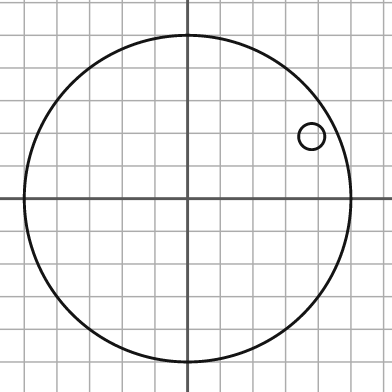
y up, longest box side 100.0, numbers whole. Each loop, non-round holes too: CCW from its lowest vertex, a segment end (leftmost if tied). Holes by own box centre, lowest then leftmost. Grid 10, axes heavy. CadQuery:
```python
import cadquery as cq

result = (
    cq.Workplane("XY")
    .moveTo(0.0, 0.0)
    .circle(50.0)
    .moveTo(38.0, 19.0)
    .circle(4.0)
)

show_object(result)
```